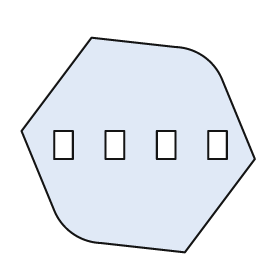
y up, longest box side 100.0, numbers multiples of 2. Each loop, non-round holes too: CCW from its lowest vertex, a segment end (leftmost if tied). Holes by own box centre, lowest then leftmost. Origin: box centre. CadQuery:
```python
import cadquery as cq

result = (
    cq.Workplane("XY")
    .moveTo(20.0, -46.0)
    .lineTo(50.0, -6.0)
    .lineTo(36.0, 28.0)
    .threePointArc((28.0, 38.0), (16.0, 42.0))
    .lineTo(-20.0, 46.0)
    .lineTo(-50.0, 6.0)
    .lineTo(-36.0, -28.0)
    .threePointArc((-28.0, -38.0), (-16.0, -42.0))
    .close()
    .moveTo(-36.0, -6.0)
    .lineTo(-28.0, -6.0)
    .lineTo(-28.0, 6.0)
    .lineTo(-36.0, 6.0)
    .close()
    .moveTo(-14.0, -6.0)
    .lineTo(-6.0, -6.0)
    .lineTo(-6.0, 6.0)
    .lineTo(-14.0, 6.0)
    .close()
    .moveTo(8.0, -6.0)
    .lineTo(16.0, -6.0)
    .lineTo(16.0, 6.0)
    .lineTo(8.0, 6.0)
    .close()
    .moveTo(30.0, -6.0)
    .lineTo(38.0, -6.0)
    .lineTo(38.0, 6.0)
    .lineTo(30.0, 6.0)
    .close()
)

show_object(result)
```